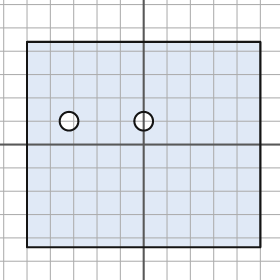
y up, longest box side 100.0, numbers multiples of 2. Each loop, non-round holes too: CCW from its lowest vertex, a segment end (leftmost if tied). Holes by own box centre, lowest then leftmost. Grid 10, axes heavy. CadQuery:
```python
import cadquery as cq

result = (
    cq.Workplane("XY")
    .moveTo(-50.0, -44.0)
    .lineTo(50.0, -44.0)
    .lineTo(50.0, 44.0)
    .lineTo(-50.0, 44.0)
    .close()
    .moveTo(-32.0, 10.0)
    .circle(4.0)
    .moveTo(0.0, 10.0)
    .circle(4.0)
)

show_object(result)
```